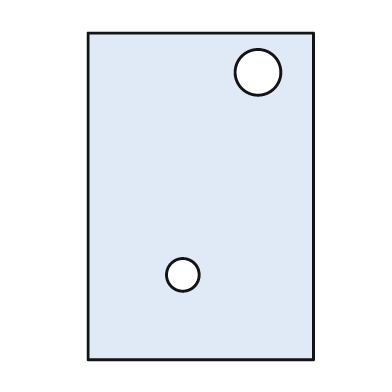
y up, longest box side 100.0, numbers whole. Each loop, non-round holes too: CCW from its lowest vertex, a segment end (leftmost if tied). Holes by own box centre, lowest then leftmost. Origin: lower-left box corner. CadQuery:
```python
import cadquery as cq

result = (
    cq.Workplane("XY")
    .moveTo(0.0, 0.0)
    .lineTo(69.0, 0.0)
    .lineTo(69.0, 100.0)
    .lineTo(0.0, 100.0)
    .close()
    .moveTo(29.0, 26.0)
    .circle(5.0)
    .moveTo(52.0, 88.0)
    .circle(7.0)
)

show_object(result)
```